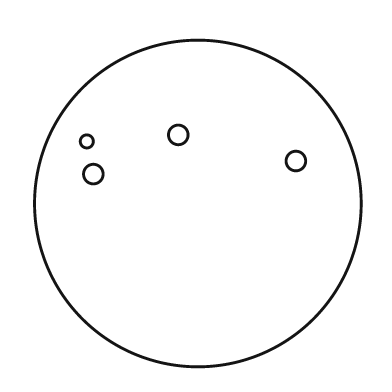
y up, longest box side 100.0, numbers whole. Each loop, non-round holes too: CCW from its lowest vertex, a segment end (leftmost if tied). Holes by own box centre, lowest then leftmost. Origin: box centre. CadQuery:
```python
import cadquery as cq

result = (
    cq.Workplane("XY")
    .moveTo(0.0, 0.0)
    .circle(50.0)
    .moveTo(-32.0, 9.0)
    .circle(3.0)
    .moveTo(30.0, 13.0)
    .circle(3.0)
    .moveTo(-34.0, 19.0)
    .circle(2.0)
    .moveTo(-6.0, 21.0)
    .circle(3.0)
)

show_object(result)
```